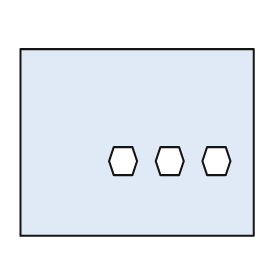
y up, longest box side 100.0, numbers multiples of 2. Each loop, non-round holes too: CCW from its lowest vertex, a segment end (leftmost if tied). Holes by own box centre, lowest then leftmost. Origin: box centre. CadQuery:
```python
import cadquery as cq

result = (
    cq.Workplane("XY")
    .moveTo(-50.0, -40.0)
    .lineTo(50.0, -40.0)
    .lineTo(50.0, 40.0)
    .lineTo(-50.0, 40.0)
    .close()
    .moveTo(-10.0, -14.0)
    .lineTo(-2.0, -14.0)
    .lineTo(0.0, -8.0)
    .lineTo(-2.0, -2.0)
    .lineTo(-10.0, -2.0)
    .lineTo(-12.0, -8.0)
    .close()
    .moveTo(10.0, -14.0)
    .lineTo(18.0, -14.0)
    .lineTo(20.0, -8.0)
    .lineTo(18.0, -2.0)
    .lineTo(10.0, -2.0)
    .lineTo(8.0, -8.0)
    .close()
    .moveTo(30.0, -14.0)
    .lineTo(38.0, -14.0)
    .lineTo(40.0, -8.0)
    .lineTo(38.0, -2.0)
    .lineTo(30.0, -2.0)
    .lineTo(28.0, -8.0)
    .close()
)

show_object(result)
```